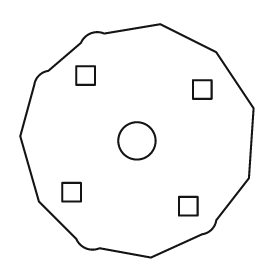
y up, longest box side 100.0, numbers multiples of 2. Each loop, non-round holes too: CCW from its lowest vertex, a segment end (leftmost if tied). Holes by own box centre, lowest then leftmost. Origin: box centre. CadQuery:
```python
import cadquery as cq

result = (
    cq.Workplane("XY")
    .moveTo(6.0, -50.0)
    .lineTo(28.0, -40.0)
    .threePointArc((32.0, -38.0), (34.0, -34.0))
    .lineTo(48.0, -16.0)
    .lineTo(50.0, 14.0)
    .lineTo(34.0, 38.0)
    .lineTo(10.0, 50.0)
    .lineTo(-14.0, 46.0)
    .threePointArc((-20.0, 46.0), (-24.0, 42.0))
    .lineTo(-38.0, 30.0)
    .threePointArc((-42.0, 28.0), (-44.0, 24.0))
    .lineTo(-50.0, 2.0)
    .lineTo(-42.0, -26.0)
    .lineTo(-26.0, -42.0)
    .threePointArc((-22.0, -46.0), (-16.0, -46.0))
    .close()
    .moveTo(18.0, -32.0)
    .lineTo(26.0, -32.0)
    .lineTo(26.0, -24.0)
    .lineTo(18.0, -24.0)
    .close()
    .moveTo(-32.0, -26.0)
    .lineTo(-24.0, -26.0)
    .lineTo(-24.0, -18.0)
    .lineTo(-32.0, -18.0)
    .close()
    .moveTo(0.0, 0.0)
    .circle(8.0)
    .moveTo(24.0, 18.0)
    .lineTo(32.0, 18.0)
    .lineTo(32.0, 26.0)
    .lineTo(24.0, 26.0)
    .close()
    .moveTo(-26.0, 24.0)
    .lineTo(-18.0, 24.0)
    .lineTo(-18.0, 32.0)
    .lineTo(-26.0, 32.0)
    .close()
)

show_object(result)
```